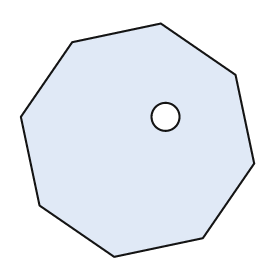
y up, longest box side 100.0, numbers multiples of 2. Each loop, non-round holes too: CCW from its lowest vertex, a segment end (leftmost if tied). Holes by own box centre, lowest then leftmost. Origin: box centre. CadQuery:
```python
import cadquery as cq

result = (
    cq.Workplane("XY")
    .moveTo(-10.0, -50.0)
    .lineTo(28.0, -42.0)
    .lineTo(50.0, -10.0)
    .lineTo(42.0, 28.0)
    .lineTo(10.0, 50.0)
    .lineTo(-28.0, 42.0)
    .lineTo(-50.0, 10.0)
    .lineTo(-42.0, -28.0)
    .close()
    .moveTo(12.0, 10.0)
    .circle(6.0)
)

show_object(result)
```